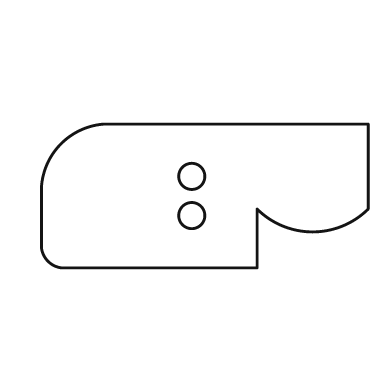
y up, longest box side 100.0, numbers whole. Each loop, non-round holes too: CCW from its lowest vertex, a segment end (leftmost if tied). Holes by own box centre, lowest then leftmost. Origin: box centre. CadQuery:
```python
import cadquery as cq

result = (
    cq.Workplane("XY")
    .moveTo(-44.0, -22.0)
    .lineTo(16.0, -22.0)
    .lineTo(16.0, -4.0)
    .threePointArc((33.0, -11.0), (50.0, -4.0))
    .lineTo(50.0, 22.0)
    .lineTo(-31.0, 22.0)
    .threePointArc((-44.0, 16.0), (-50.0, 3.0))
    .lineTo(-50.0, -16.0)
    .threePointArc((-48.0, -20.0), (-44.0, -22.0))
    .close()
    .moveTo(-4.0, -6.0)
    .circle(4.0)
    .moveTo(-4.0, 6.0)
    .circle(4.0)
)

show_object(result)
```